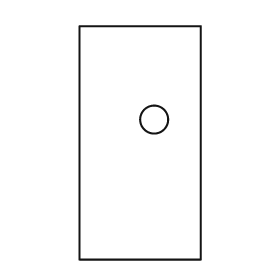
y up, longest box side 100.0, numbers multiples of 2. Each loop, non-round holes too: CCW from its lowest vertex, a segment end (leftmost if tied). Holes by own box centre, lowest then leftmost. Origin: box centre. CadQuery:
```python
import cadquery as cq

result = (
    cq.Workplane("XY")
    .moveTo(-26.0, -50.0)
    .lineTo(26.0, -50.0)
    .lineTo(26.0, 50.0)
    .lineTo(-26.0, 50.0)
    .close()
    .moveTo(6.0, 10.0)
    .circle(6.0)
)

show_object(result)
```